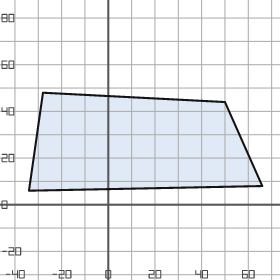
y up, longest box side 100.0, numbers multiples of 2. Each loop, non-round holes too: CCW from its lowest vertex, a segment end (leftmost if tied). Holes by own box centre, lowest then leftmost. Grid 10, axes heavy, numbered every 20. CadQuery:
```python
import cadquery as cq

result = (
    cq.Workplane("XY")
    .moveTo(-34.0, 6.0)
    .lineTo(66.0, 8.0)
    .lineTo(50.0, 44.0)
    .lineTo(-28.0, 48.0)
    .close()
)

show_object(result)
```